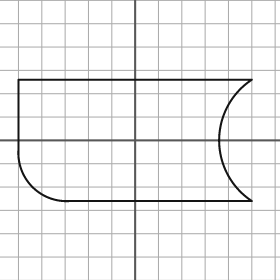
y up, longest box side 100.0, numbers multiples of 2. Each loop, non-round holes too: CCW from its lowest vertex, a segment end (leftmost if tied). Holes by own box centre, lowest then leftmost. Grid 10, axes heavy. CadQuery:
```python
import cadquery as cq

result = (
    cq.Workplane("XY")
    .moveTo(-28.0, -26.0)
    .lineTo(50.0, -26.0)
    .threePointArc((36.0, 0.0), (50.0, 26.0))
    .lineTo(-50.0, 26.0)
    .lineTo(-50.0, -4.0)
    .threePointArc((-44.0, -20.0), (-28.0, -26.0))
    .close()
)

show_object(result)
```